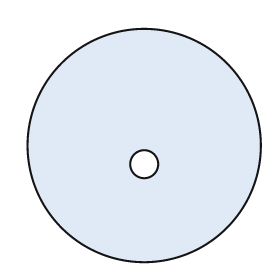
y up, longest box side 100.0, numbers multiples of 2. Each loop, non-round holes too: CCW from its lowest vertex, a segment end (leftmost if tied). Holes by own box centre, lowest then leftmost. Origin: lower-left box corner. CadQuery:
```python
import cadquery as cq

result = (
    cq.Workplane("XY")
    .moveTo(50.0, 50.0)
    .circle(50.0)
    .moveTo(50.0, 42.0)
    .circle(6.0)
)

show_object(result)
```